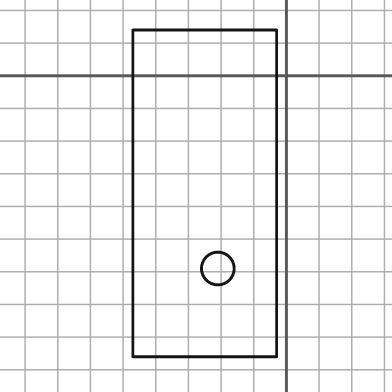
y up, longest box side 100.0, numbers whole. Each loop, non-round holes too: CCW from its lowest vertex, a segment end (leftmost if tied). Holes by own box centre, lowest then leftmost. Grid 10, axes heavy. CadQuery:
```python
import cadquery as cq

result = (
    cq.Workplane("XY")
    .moveTo(-47.0, -86.0)
    .lineTo(-3.0, -86.0)
    .lineTo(-3.0, 14.0)
    .lineTo(-47.0, 14.0)
    .close()
    .moveTo(-21.0, -59.0)
    .circle(5.0)
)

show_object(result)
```